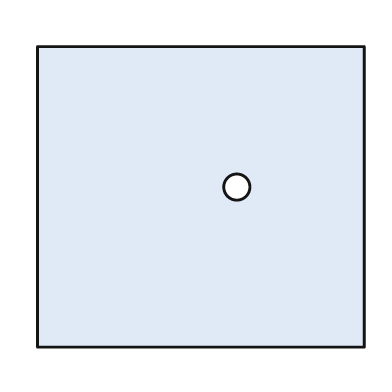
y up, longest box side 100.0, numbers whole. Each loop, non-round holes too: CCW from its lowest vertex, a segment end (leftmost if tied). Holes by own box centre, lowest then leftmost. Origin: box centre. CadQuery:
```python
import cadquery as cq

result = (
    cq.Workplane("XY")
    .moveTo(-50.0, -46.0)
    .lineTo(50.0, -46.0)
    .lineTo(50.0, 46.0)
    .lineTo(-50.0, 46.0)
    .close()
    .moveTo(11.0, 3.0)
    .circle(4.0)
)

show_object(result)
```